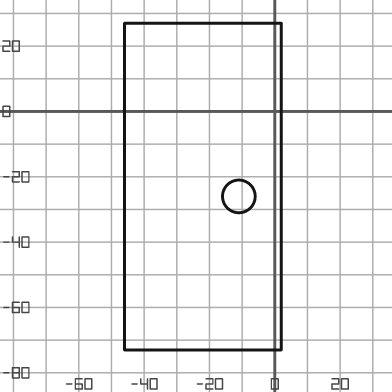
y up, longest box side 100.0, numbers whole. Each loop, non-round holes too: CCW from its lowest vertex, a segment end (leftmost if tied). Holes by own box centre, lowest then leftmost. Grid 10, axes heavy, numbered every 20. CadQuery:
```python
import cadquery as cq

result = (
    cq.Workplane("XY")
    .moveTo(-46.0, -73.0)
    .lineTo(2.0, -73.0)
    .lineTo(2.0, 27.0)
    .lineTo(-46.0, 27.0)
    .close()
    .moveTo(-11.0, -26.0)
    .circle(5.0)
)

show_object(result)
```